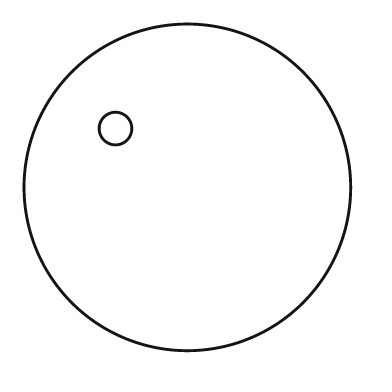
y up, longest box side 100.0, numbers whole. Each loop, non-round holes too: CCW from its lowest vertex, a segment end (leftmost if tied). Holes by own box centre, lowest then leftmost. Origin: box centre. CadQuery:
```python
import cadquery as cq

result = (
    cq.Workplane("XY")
    .moveTo(0.0, 0.0)
    .circle(50.0)
    .moveTo(-22.0, 18.0)
    .circle(5.0)
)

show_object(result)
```